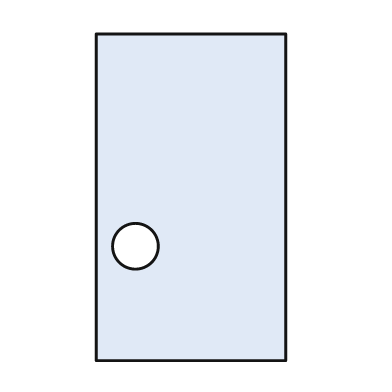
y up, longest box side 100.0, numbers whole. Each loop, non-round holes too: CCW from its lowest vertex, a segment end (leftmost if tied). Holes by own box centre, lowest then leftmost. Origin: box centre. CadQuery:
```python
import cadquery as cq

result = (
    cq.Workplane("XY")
    .moveTo(-29.0, -50.0)
    .lineTo(29.0, -50.0)
    .lineTo(29.0, 50.0)
    .lineTo(-29.0, 50.0)
    .close()
    .moveTo(-17.0, -15.0)
    .circle(7.0)
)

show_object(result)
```